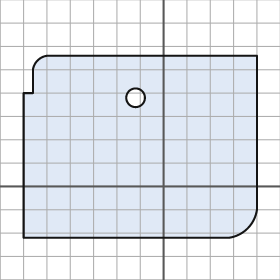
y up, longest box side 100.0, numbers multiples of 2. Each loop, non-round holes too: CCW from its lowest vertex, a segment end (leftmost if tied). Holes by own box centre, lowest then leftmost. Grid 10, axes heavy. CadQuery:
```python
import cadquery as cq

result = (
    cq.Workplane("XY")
    .moveTo(-60.0, -22.0)
    .lineTo(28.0, -22.0)
    .threePointArc((36.0, -18.0), (40.0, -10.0))
    .lineTo(40.0, 56.0)
    .lineTo(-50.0, 56.0)
    .threePointArc((-54.0, 54.0), (-56.0, 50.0))
    .lineTo(-56.0, 40.0)
    .lineTo(-60.0, 40.0)
    .close()
    .moveTo(-12.0, 38.0)
    .circle(4.0)
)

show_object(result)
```